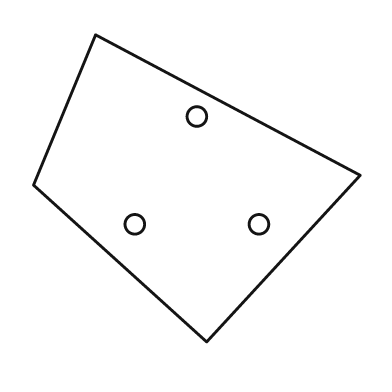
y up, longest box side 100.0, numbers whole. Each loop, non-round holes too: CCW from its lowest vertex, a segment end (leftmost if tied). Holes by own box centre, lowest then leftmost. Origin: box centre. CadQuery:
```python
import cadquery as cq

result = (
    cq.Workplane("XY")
    .moveTo(3.0, -47.0)
    .lineTo(50.0, 4.0)
    .lineTo(-31.0, 47.0)
    .lineTo(-50.0, 1.0)
    .close()
    .moveTo(-19.0, -11.0)
    .circle(3.0)
    .moveTo(19.0, -11.0)
    .circle(3.0)
    .moveTo(0.0, 22.0)
    .circle(3.0)
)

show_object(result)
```